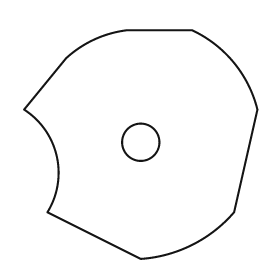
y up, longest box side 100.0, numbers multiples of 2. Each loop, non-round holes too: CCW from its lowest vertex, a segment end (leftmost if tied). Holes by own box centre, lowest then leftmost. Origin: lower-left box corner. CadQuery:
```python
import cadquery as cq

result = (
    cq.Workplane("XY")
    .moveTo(50.0, 0.0)
    .threePointArc((72.0, 6.0), (90.0, 20.0))
    .lineTo(100.0, 64.0)
    .threePointArc((90.0, 84.0), (72.0, 98.0))
    .lineTo(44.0, 98.0)
    .threePointArc((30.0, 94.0), (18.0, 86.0))
    .lineTo(0.0, 64.0)
    .threePointArc((14.0, 44.0), (10.0, 20.0))
    .close()
    .moveTo(50.0, 50.0)
    .circle(8.0)
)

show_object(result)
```